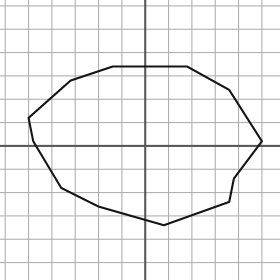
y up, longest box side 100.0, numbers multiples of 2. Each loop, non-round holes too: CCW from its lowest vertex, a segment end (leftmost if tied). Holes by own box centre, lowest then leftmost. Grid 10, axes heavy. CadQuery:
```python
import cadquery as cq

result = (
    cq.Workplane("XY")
    .moveTo(8.0, -34.0)
    .lineTo(36.0, -24.0)
    .lineTo(38.0, -14.0)
    .lineTo(50.0, 2.0)
    .lineTo(36.0, 24.0)
    .lineTo(18.0, 34.0)
    .lineTo(-14.0, 34.0)
    .lineTo(-32.0, 28.0)
    .lineTo(-50.0, 12.0)
    .lineTo(-48.0, 2.0)
    .lineTo(-36.0, -18.0)
    .lineTo(-20.0, -26.0)
    .close()
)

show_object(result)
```